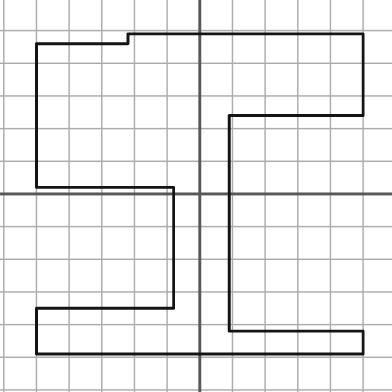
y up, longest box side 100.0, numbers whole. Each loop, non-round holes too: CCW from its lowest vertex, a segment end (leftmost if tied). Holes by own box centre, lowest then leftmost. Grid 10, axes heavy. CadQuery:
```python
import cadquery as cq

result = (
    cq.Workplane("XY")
    .moveTo(-50.0, -49.0)
    .lineTo(50.0, -49.0)
    .lineTo(50.0, -42.0)
    .lineTo(9.0, -42.0)
    .lineTo(9.0, 24.0)
    .lineTo(50.0, 24.0)
    .lineTo(50.0, 49.0)
    .lineTo(-22.0, 49.0)
    .lineTo(-22.0, 46.0)
    .lineTo(-50.0, 46.0)
    .lineTo(-50.0, 2.0)
    .lineTo(-8.0, 2.0)
    .lineTo(-8.0, -35.0)
    .lineTo(-50.0, -35.0)
    .close()
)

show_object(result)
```